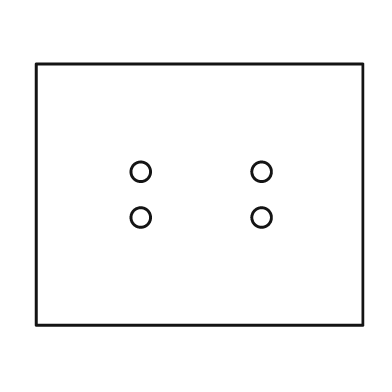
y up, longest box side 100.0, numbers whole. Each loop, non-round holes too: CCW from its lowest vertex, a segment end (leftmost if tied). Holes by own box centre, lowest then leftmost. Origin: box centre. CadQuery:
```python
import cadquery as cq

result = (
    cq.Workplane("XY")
    .moveTo(-50.0, -40.0)
    .lineTo(50.0, -40.0)
    .lineTo(50.0, 40.0)
    .lineTo(-50.0, 40.0)
    .close()
    .moveTo(-18.0, -7.0)
    .circle(3.0)
    .moveTo(19.0, -7.0)
    .circle(3.0)
    .moveTo(-18.0, 7.0)
    .circle(3.0)
    .moveTo(19.0, 7.0)
    .circle(3.0)
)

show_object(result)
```